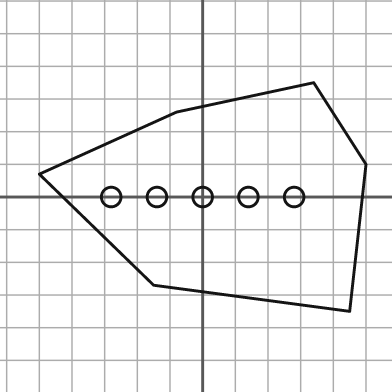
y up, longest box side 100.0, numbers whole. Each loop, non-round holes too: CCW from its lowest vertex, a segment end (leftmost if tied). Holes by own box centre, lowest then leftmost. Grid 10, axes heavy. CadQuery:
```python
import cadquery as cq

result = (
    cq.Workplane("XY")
    .moveTo(45.0, -35.0)
    .lineTo(50.0, 10.0)
    .lineTo(34.0, 35.0)
    .lineTo(-8.0, 26.0)
    .lineTo(-50.0, 7.0)
    .lineTo(-15.0, -27.0)
    .close()
    .moveTo(-28.0, 0.0)
    .circle(3.0)
    .moveTo(-14.0, 0.0)
    .circle(3.0)
    .moveTo(0.0, 0.0)
    .circle(3.0)
    .moveTo(14.0, 0.0)
    .circle(3.0)
    .moveTo(28.0, 0.0)
    .circle(3.0)
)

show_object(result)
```